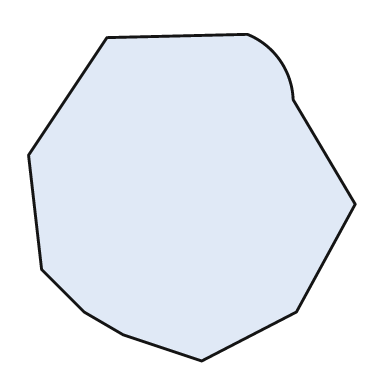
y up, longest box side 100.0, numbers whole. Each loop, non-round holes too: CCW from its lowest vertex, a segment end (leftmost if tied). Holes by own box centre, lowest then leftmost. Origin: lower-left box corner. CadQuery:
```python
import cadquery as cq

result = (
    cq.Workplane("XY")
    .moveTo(53.0, 0.0)
    .lineTo(82.0, 15.0)
    .lineTo(100.0, 48.0)
    .lineTo(81.0, 80.0)
    .threePointArc((77.0, 92.0), (67.0, 100.0))
    .lineTo(24.0, 99.0)
    .lineTo(0.0, 63.0)
    .lineTo(4.0, 28.0)
    .lineTo(17.0, 15.0)
    .lineTo(29.0, 8.0)
    .close()
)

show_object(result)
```